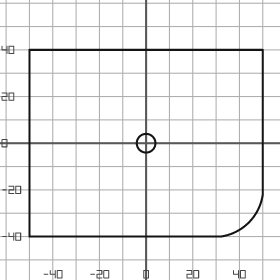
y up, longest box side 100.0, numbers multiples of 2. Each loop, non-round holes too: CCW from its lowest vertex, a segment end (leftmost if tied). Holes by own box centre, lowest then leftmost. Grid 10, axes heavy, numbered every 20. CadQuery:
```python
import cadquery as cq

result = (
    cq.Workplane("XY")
    .moveTo(-50.0, -40.0)
    .lineTo(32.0, -40.0)
    .threePointArc((44.0, -34.0), (50.0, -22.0))
    .lineTo(50.0, 40.0)
    .lineTo(-50.0, 40.0)
    .close()
    .moveTo(0.0, 0.0)
    .circle(4.0)
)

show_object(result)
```